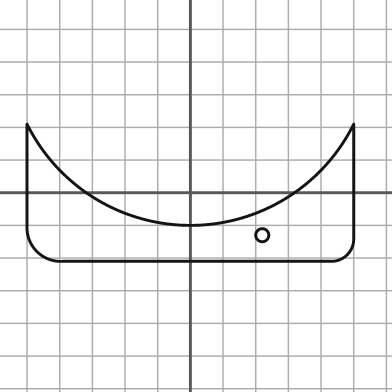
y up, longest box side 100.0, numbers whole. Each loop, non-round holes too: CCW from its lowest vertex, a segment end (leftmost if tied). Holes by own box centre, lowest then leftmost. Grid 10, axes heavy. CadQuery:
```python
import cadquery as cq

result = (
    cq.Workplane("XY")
    .moveTo(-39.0, -21.0)
    .lineTo(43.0, -21.0)
    .threePointArc((48.0, -19.0), (50.0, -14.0))
    .lineTo(50.0, 21.0)
    .threePointArc((0.0, -10.0), (-50.0, 21.0))
    .lineTo(-50.0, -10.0)
    .threePointArc((-47.0, -18.0), (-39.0, -21.0))
    .close()
    .moveTo(22.0, -13.0)
    .circle(2.0)
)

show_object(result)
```